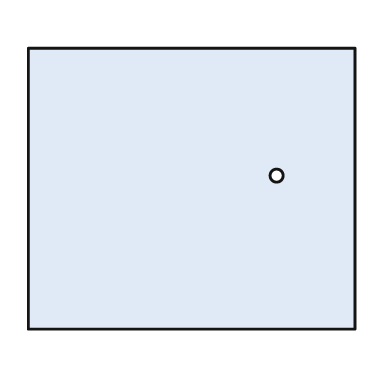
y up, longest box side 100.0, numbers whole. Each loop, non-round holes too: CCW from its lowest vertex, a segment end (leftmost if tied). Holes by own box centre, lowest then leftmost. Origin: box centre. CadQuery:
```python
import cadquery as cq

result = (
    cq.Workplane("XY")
    .moveTo(-50.0, -43.0)
    .lineTo(50.0, -43.0)
    .lineTo(50.0, 43.0)
    .lineTo(-50.0, 43.0)
    .close()
    .moveTo(26.0, 4.0)
    .circle(2.0)
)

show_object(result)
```